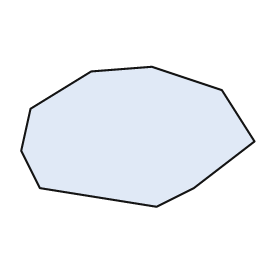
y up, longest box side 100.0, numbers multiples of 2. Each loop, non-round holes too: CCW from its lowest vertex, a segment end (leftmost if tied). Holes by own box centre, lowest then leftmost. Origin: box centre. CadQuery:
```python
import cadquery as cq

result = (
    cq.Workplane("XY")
    .moveTo(8.0, -30.0)
    .lineTo(24.0, -22.0)
    .lineTo(50.0, -2.0)
    .lineTo(36.0, 20.0)
    .lineTo(6.0, 30.0)
    .lineTo(-20.0, 28.0)
    .lineTo(-46.0, 12.0)
    .lineTo(-50.0, -6.0)
    .lineTo(-42.0, -22.0)
    .close()
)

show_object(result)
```